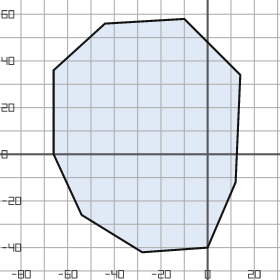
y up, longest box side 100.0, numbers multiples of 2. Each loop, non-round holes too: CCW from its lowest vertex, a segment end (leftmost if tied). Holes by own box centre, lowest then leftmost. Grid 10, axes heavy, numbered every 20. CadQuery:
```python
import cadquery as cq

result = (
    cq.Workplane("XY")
    .moveTo(-28.0, -42.0)
    .lineTo(0.0, -40.0)
    .lineTo(12.0, -12.0)
    .lineTo(14.0, 34.0)
    .lineTo(-10.0, 58.0)
    .lineTo(-44.0, 56.0)
    .lineTo(-66.0, 36.0)
    .lineTo(-66.0, 0.0)
    .lineTo(-54.0, -26.0)
    .close()
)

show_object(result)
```